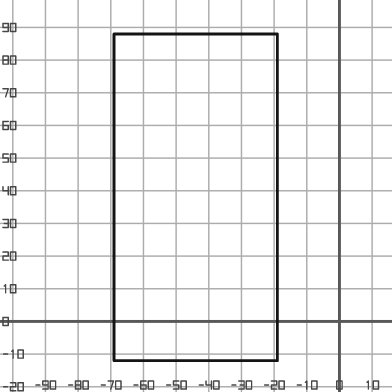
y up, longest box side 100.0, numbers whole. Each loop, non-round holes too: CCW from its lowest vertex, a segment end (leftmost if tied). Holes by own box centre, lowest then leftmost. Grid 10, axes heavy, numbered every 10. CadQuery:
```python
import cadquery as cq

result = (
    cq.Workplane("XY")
    .moveTo(-69.0, -12.0)
    .lineTo(-19.0, -12.0)
    .lineTo(-19.0, 88.0)
    .lineTo(-69.0, 88.0)
    .close()
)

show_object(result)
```